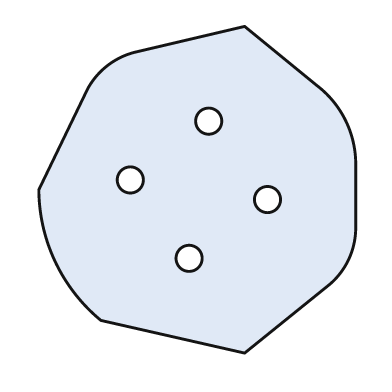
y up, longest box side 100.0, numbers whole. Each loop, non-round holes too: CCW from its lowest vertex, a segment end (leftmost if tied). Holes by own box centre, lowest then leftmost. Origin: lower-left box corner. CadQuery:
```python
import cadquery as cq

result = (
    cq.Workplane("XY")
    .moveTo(63.0, 0.0)
    .lineTo(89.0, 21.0)
    .threePointArc((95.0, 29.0), (97.0, 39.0))
    .lineTo(97.0, 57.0)
    .threePointArc((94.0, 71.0), (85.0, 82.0))
    .lineTo(63.0, 100.0)
    .lineTo(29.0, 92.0)
    .threePointArc((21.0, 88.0), (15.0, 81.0))
    .lineTo(0.0, 50.0)
    .threePointArc((5.0, 28.0), (19.0, 10.0))
    .close()
    .moveTo(46.0, 29.0)
    .circle(4.0)
    .moveTo(70.0, 47.0)
    .circle(4.0)
    .moveTo(28.0, 53.0)
    .circle(4.0)
    .moveTo(52.0, 71.0)
    .circle(4.0)
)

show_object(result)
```